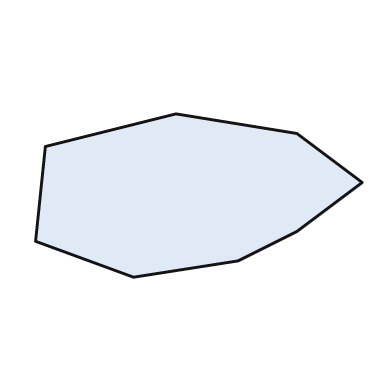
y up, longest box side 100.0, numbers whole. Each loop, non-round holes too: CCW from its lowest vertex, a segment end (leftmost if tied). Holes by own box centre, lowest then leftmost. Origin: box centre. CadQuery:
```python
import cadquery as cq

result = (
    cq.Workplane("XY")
    .moveTo(-20.0, -25.0)
    .lineTo(12.0, -20.0)
    .lineTo(30.0, -11.0)
    .lineTo(50.0, 4.0)
    .lineTo(30.0, 19.0)
    .lineTo(-7.0, 25.0)
    .lineTo(-47.0, 15.0)
    .lineTo(-50.0, -14.0)
    .close()
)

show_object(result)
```